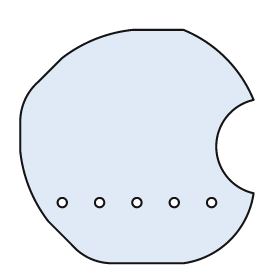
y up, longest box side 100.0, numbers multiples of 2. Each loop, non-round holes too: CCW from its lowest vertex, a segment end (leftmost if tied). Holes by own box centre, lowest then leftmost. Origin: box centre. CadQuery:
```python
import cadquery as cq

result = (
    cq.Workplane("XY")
    .moveTo(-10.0, -50.0)
    .lineTo(20.0, -50.0)
    .threePointArc((40.0, -40.0), (50.0, -20.0))
    .threePointArc((34.0, 0.0), (50.0, 20.0))
    .threePointArc((38.0, 38.0), (20.0, 50.0))
    .lineTo(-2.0, 50.0)
    .threePointArc((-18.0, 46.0), (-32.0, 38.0))
    .lineTo(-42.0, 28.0)
    .threePointArc((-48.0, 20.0), (-50.0, 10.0))
    .lineTo(-50.0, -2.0)
    .threePointArc((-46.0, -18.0), (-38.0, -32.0))
    .lineTo(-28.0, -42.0)
    .threePointArc((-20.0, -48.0), (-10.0, -50.0))
    .close()
    .moveTo(-32.0, -24.0)
    .circle(2.0)
    .moveTo(-16.0, -24.0)
    .circle(2.0)
    .moveTo(0.0, -24.0)
    .circle(2.0)
    .moveTo(16.0, -24.0)
    .circle(2.0)
    .moveTo(32.0, -24.0)
    .circle(2.0)
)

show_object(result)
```